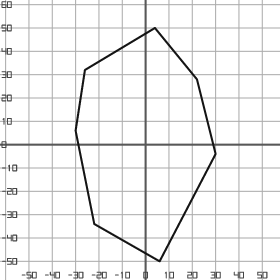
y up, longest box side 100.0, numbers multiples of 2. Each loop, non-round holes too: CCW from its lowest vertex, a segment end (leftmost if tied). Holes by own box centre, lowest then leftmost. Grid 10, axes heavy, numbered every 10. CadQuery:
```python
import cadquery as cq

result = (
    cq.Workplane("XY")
    .moveTo(6.0, -50.0)
    .lineTo(30.0, -4.0)
    .lineTo(22.0, 28.0)
    .lineTo(4.0, 50.0)
    .lineTo(-26.0, 32.0)
    .lineTo(-30.0, 6.0)
    .lineTo(-22.0, -34.0)
    .close()
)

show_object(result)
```